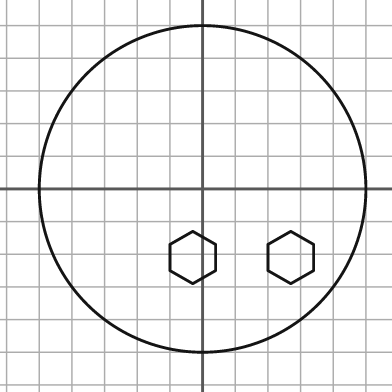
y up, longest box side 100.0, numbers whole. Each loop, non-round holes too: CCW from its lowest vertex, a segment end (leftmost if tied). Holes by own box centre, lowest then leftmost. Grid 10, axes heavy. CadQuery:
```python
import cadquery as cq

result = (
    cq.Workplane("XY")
    .moveTo(0.0, 0.0)
    .circle(50.0)
    .moveTo(-3.0, -29.0)
    .lineTo(4.0, -25.0)
    .lineTo(4.0, -17.0)
    .lineTo(-3.0, -13.0)
    .lineTo(-10.0, -17.0)
    .lineTo(-10.0, -25.0)
    .close()
    .moveTo(27.0, -29.0)
    .lineTo(34.0, -25.0)
    .lineTo(34.0, -17.0)
    .lineTo(27.0, -13.0)
    .lineTo(20.0, -17.0)
    .lineTo(20.0, -25.0)
    .close()
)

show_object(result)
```